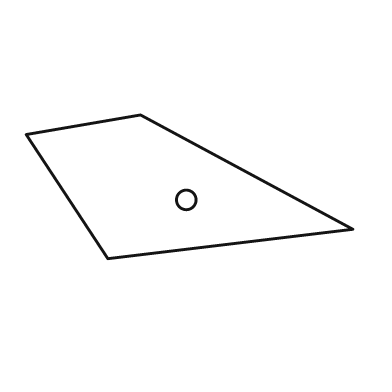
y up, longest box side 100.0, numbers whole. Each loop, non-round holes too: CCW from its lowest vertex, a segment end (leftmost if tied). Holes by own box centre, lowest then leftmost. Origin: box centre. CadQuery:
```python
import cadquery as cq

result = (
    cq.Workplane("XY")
    .moveTo(-25.0, -22.0)
    .lineTo(50.0, -13.0)
    .lineTo(-15.0, 22.0)
    .lineTo(-50.0, 16.0)
    .close()
    .moveTo(-1.0, -4.0)
    .circle(3.0)
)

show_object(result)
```